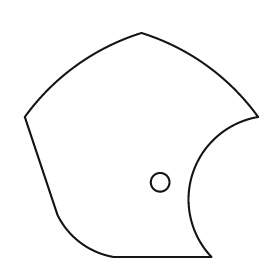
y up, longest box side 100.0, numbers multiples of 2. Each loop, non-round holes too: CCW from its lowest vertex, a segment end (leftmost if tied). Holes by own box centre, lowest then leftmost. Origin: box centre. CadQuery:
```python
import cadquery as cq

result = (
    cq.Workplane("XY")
    .moveTo(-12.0, -48.0)
    .lineTo(30.0, -48.0)
    .threePointArc((22.0, -12.0), (50.0, 12.0))
    .threePointArc((28.0, 34.0), (0.0, 48.0))
    .threePointArc((-28.0, 34.0), (-50.0, 12.0))
    .lineTo(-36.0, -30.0)
    .threePointArc((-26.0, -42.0), (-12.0, -48.0))
    .close()
    .moveTo(8.0, -16.0)
    .circle(4.0)
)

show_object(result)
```